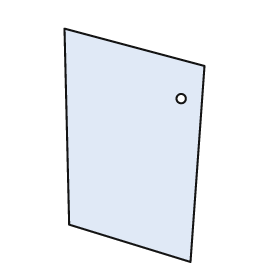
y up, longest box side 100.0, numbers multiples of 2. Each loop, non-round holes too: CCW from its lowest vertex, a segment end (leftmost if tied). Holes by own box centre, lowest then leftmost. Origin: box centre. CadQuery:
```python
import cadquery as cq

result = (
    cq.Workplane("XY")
    .moveTo(24.0, -50.0)
    .lineTo(30.0, 34.0)
    .lineTo(-30.0, 50.0)
    .lineTo(-28.0, -34.0)
    .close()
    .moveTo(20.0, 20.0)
    .circle(2.0)
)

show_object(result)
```